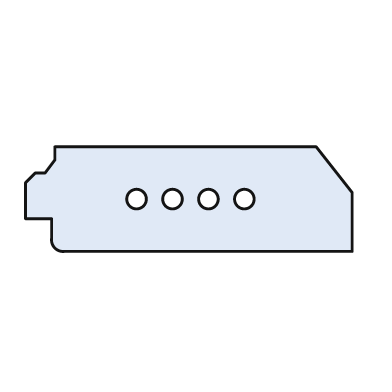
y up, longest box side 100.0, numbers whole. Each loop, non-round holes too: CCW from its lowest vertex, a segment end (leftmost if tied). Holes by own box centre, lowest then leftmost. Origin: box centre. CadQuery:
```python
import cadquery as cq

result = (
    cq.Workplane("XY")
    .moveTo(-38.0, -16.0)
    .lineTo(50.0, -16.0)
    .lineTo(50.0, 2.0)
    .lineTo(39.0, 16.0)
    .lineTo(-41.0, 16.0)
    .lineTo(-41.0, 12.0)
    .lineTo(-44.0, 8.0)
    .lineTo(-47.0, 8.0)
    .lineTo(-50.0, 5.0)
    .lineTo(-50.0, -6.0)
    .lineTo(-42.0, -6.0)
    .lineTo(-42.0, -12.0)
    .threePointArc((-41.0, -15.0), (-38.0, -16.0))
    .close()
    .moveTo(-16.0, 0.0)
    .circle(3.0)
    .moveTo(-5.0, 0.0)
    .circle(3.0)
    .moveTo(6.0, 0.0)
    .circle(3.0)
    .moveTo(17.0, 0.0)
    .circle(3.0)
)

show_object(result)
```